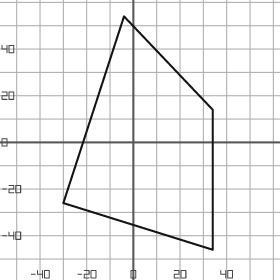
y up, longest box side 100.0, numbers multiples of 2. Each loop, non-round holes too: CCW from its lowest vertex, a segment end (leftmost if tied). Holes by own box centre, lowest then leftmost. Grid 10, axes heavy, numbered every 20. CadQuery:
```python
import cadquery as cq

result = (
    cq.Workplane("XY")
    .moveTo(34.0, -46.0)
    .lineTo(34.0, 14.0)
    .lineTo(-4.0, 54.0)
    .lineTo(-30.0, -26.0)
    .close()
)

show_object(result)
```